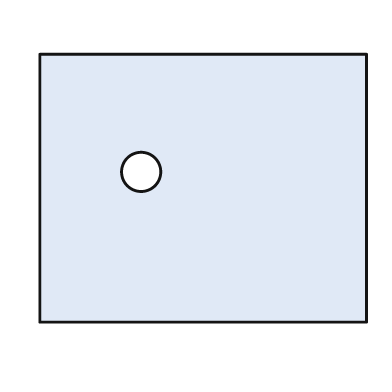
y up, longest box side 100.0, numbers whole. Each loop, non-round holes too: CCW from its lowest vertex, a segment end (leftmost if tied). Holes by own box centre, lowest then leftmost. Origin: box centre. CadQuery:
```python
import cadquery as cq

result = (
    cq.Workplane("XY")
    .moveTo(-50.0, -41.0)
    .lineTo(50.0, -41.0)
    .lineTo(50.0, 41.0)
    .lineTo(-50.0, 41.0)
    .close()
    .moveTo(-19.0, 5.0)
    .circle(6.0)
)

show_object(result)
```